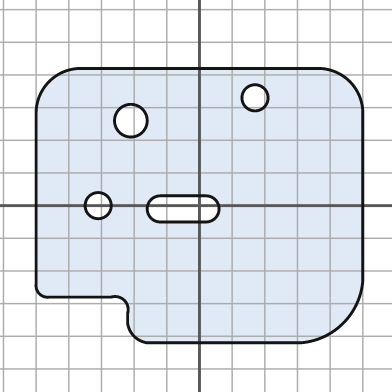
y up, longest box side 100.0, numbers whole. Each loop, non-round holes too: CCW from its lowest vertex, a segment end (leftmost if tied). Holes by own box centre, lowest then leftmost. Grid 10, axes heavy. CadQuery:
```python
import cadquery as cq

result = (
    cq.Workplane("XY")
    .moveTo(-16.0, -42.0)
    .lineTo(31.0, -42.0)
    .threePointArc((44.0, -36.0), (50.0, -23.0))
    .lineTo(50.0, 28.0)
    .threePointArc((46.0, 38.0), (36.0, 42.0))
    .lineTo(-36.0, 42.0)
    .threePointArc((-46.0, 38.0), (-50.0, 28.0))
    .lineTo(-50.0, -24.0)
    .threePointArc((-49.0, -27.0), (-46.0, -28.0))
    .lineTo(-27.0, -28.0)
    .threePointArc((-23.0, -29.0), (-22.0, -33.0))
    .lineTo(-22.0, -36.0)
    .threePointArc((-20.0, -40.0), (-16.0, -42.0))
    .close()
    .moveTo(-12.0, -5.0)
    .lineTo(2.0, -5.0)
    .threePointArc((6.0, -1.0), (2.0, 3.0))
    .lineTo(-12.0, 3.0)
    .threePointArc((-16.0, -1.0), (-12.0, -5.0))
    .close()
    .moveTo(-31.0, 0.0)
    .circle(4.0)
    .moveTo(-21.0, 26.0)
    .circle(5.0)
    .moveTo(17.0, 33.0)
    .circle(4.0)
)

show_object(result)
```